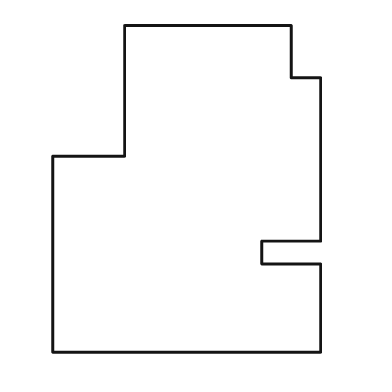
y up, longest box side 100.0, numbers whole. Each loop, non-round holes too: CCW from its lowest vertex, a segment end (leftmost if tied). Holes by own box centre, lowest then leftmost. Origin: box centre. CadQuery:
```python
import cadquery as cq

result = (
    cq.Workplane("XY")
    .moveTo(-41.0, -50.0)
    .lineTo(41.0, -50.0)
    .lineTo(41.0, -23.0)
    .lineTo(23.0, -23.0)
    .lineTo(23.0, -16.0)
    .lineTo(41.0, -16.0)
    .lineTo(41.0, 34.0)
    .lineTo(32.0, 34.0)
    .lineTo(32.0, 50.0)
    .lineTo(-19.0, 50.0)
    .lineTo(-19.0, 10.0)
    .lineTo(-41.0, 10.0)
    .close()
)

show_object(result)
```